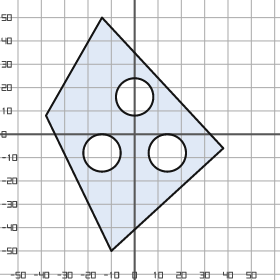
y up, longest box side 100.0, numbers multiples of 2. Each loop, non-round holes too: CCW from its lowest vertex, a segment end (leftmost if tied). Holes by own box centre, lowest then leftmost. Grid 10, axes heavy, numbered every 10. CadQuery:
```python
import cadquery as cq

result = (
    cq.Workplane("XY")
    .moveTo(-10.0, -50.0)
    .lineTo(38.0, -6.0)
    .lineTo(-14.0, 50.0)
    .lineTo(-38.0, 8.0)
    .close()
    .moveTo(-14.0, -8.0)
    .circle(8.0)
    .moveTo(14.0, -8.0)
    .circle(8.0)
    .moveTo(0.0, 16.0)
    .circle(8.0)
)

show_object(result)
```